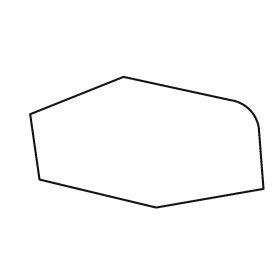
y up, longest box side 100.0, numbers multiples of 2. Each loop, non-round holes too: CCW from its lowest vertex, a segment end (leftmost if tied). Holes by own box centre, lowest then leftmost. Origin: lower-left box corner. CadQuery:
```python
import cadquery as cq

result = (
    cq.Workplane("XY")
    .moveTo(54.0, 0.0)
    .lineTo(100.0, 8.0)
    .lineTo(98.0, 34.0)
    .threePointArc((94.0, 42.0), (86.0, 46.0))
    .lineTo(40.0, 56.0)
    .lineTo(0.0, 40.0)
    .lineTo(4.0, 12.0)
    .close()
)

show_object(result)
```